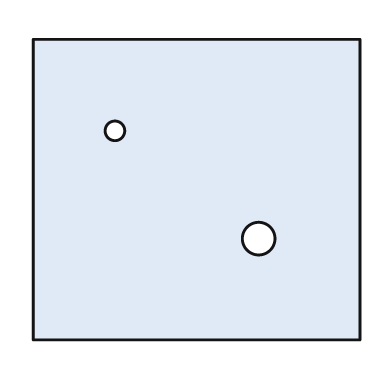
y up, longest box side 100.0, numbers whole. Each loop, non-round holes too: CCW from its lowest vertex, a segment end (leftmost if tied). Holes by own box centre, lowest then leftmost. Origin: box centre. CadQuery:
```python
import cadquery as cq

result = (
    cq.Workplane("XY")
    .moveTo(-50.0, -46.0)
    .lineTo(50.0, -46.0)
    .lineTo(50.0, 46.0)
    .lineTo(-50.0, 46.0)
    .close()
    .moveTo(19.0, -15.0)
    .circle(5.0)
    .moveTo(-25.0, 18.0)
    .circle(3.0)
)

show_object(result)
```